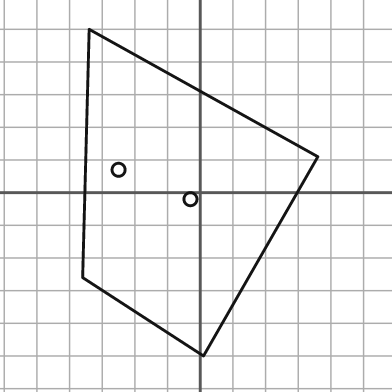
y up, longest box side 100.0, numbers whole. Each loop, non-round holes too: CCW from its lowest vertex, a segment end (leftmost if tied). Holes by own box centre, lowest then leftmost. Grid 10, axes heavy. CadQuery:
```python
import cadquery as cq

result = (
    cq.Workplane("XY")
    .moveTo(1.0, -50.0)
    .lineTo(36.0, 11.0)
    .lineTo(-34.0, 50.0)
    .lineTo(-36.0, -26.0)
    .close()
    .moveTo(-3.0, -2.0)
    .circle(2.0)
    .moveTo(-25.0, 7.0)
    .circle(2.0)
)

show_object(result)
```